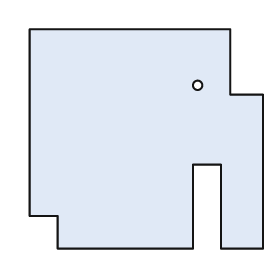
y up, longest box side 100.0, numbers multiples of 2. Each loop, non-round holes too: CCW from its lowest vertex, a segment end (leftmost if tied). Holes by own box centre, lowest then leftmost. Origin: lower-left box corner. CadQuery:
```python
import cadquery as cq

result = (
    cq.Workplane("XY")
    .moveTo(12.0, 0.0)
    .lineTo(70.0, 0.0)
    .lineTo(70.0, 36.0)
    .lineTo(82.0, 36.0)
    .lineTo(82.0, 0.0)
    .lineTo(100.0, 0.0)
    .lineTo(100.0, 66.0)
    .lineTo(86.0, 66.0)
    .lineTo(86.0, 94.0)
    .lineTo(0.0, 94.0)
    .lineTo(0.0, 14.0)
    .lineTo(12.0, 14.0)
    .close()
    .moveTo(72.0, 70.0)
    .circle(2.0)
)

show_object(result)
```